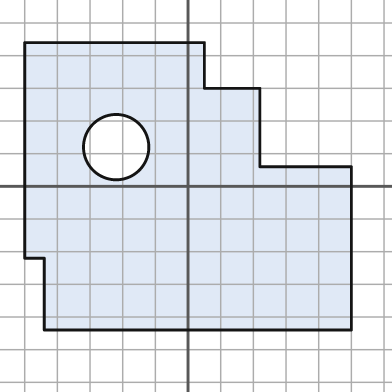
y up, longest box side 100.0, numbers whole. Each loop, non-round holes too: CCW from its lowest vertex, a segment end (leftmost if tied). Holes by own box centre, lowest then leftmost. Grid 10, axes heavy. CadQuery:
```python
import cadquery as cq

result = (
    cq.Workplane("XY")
    .moveTo(-44.0, -44.0)
    .lineTo(50.0, -44.0)
    .lineTo(50.0, 6.0)
    .lineTo(22.0, 6.0)
    .lineTo(22.0, 30.0)
    .lineTo(5.0, 30.0)
    .lineTo(5.0, 44.0)
    .lineTo(-50.0, 44.0)
    .lineTo(-50.0, -22.0)
    .lineTo(-44.0, -22.0)
    .close()
    .moveTo(-22.0, 12.0)
    .circle(10.0)
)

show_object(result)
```